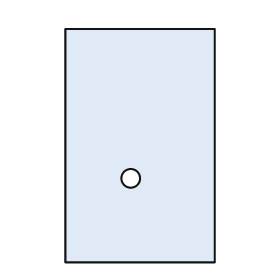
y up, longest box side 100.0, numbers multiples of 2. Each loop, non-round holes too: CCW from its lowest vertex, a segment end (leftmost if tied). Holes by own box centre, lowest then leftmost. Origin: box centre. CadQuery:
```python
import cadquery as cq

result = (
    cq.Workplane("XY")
    .moveTo(-32.0, -50.0)
    .lineTo(32.0, -50.0)
    .lineTo(32.0, 50.0)
    .lineTo(-32.0, 50.0)
    .close()
    .moveTo(-4.0, -14.0)
    .circle(4.0)
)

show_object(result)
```